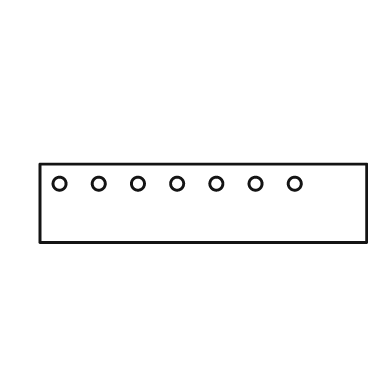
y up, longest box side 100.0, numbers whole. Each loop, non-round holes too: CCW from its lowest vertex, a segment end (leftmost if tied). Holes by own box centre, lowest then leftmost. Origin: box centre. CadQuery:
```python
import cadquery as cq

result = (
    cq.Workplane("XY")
    .moveTo(-50.0, -12.0)
    .lineTo(50.0, -12.0)
    .lineTo(50.0, 12.0)
    .lineTo(-50.0, 12.0)
    .close()
    .moveTo(-44.0, 6.0)
    .circle(2.0)
    .moveTo(-32.0, 6.0)
    .circle(2.0)
    .moveTo(-20.0, 6.0)
    .circle(2.0)
    .moveTo(-8.0, 6.0)
    .circle(2.0)
    .moveTo(4.0, 6.0)
    .circle(2.0)
    .moveTo(16.0, 6.0)
    .circle(2.0)
    .moveTo(28.0, 6.0)
    .circle(2.0)
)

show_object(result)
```